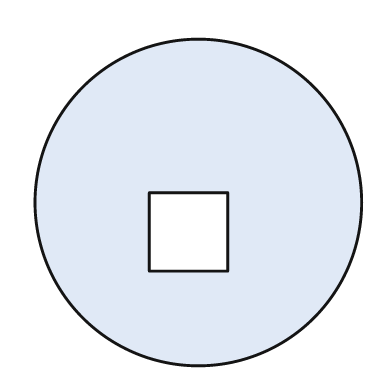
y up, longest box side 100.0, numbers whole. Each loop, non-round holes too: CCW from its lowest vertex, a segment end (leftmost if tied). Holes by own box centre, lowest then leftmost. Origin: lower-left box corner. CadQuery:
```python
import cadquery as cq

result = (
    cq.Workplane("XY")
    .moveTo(50.0, 50.0)
    .circle(50.0)
    .moveTo(35.0, 29.0)
    .lineTo(59.0, 29.0)
    .lineTo(59.0, 53.0)
    .lineTo(35.0, 53.0)
    .close()
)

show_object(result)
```